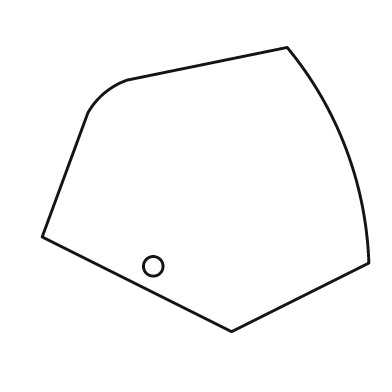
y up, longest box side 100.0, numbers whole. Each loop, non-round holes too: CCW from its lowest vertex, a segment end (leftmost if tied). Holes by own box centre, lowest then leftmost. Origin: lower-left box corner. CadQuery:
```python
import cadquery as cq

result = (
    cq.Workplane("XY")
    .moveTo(58.0, 0.0)
    .lineTo(100.0, 21.0)
    .threePointArc((93.0, 56.0), (75.0, 87.0))
    .lineTo(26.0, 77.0)
    .threePointArc((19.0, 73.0), (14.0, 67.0))
    .lineTo(0.0, 29.0)
    .close()
    .moveTo(34.0, 20.0)
    .circle(3.0)
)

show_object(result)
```